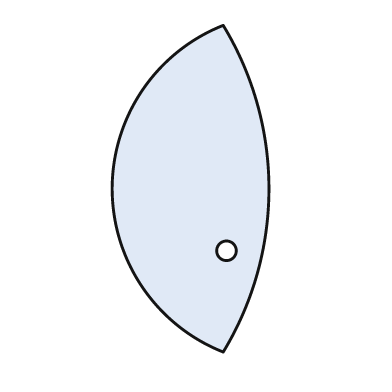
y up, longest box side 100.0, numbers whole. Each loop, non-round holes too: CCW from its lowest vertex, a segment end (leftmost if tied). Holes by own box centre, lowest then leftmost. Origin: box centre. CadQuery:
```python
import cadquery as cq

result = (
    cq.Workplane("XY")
    .moveTo(10.0, -50.0)
    .threePointArc((24.0, 0.0), (10.0, 50.0))
    .threePointArc((-24.0, 0.0), (10.0, -50.0))
    .close()
    .moveTo(11.0, -19.0)
    .circle(3.0)
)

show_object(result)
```